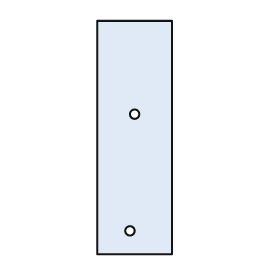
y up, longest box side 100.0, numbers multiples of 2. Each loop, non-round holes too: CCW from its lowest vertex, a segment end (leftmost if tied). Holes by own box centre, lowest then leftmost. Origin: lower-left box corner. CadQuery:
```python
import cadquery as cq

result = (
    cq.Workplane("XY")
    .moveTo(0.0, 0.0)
    .lineTo(32.0, 0.0)
    .lineTo(32.0, 100.0)
    .lineTo(0.0, 100.0)
    .close()
    .moveTo(14.0, 10.0)
    .circle(2.0)
    .moveTo(16.0, 60.0)
    .circle(2.0)
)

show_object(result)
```